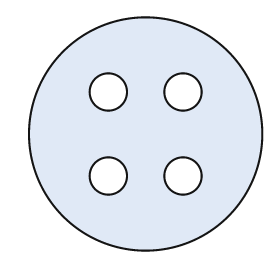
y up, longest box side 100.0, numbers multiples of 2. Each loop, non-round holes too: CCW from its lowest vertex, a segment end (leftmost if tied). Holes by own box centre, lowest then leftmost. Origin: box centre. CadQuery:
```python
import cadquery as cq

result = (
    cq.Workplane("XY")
    .moveTo(0.0, 0.0)
    .circle(50.0)
    .moveTo(-16.0, -18.0)
    .circle(8.0)
    .moveTo(16.0, -18.0)
    .circle(8.0)
    .moveTo(-16.0, 18.0)
    .circle(8.0)
    .moveTo(16.0, 18.0)
    .circle(8.0)
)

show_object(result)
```